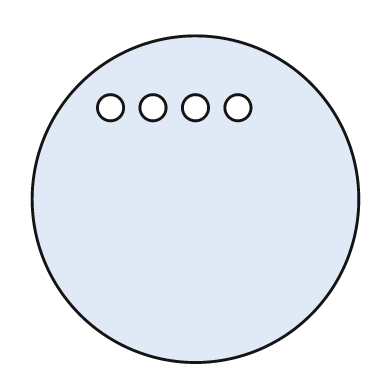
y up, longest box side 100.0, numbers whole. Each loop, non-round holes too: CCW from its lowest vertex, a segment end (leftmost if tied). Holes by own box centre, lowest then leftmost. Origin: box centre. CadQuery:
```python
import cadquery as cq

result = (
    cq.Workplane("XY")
    .moveTo(0.0, 0.0)
    .circle(50.0)
    .moveTo(-26.0, 28.0)
    .circle(4.0)
    .moveTo(-13.0, 28.0)
    .circle(4.0)
    .moveTo(0.0, 28.0)
    .circle(4.0)
    .moveTo(13.0, 28.0)
    .circle(4.0)
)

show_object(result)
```